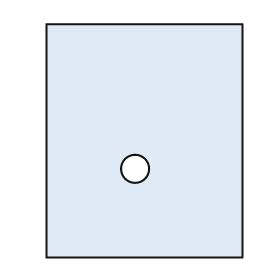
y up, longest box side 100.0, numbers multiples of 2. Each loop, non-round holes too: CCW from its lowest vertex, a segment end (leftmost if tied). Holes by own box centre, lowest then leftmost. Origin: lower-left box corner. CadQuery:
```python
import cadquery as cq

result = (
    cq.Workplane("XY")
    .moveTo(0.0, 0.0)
    .lineTo(84.0, 0.0)
    .lineTo(84.0, 100.0)
    .lineTo(0.0, 100.0)
    .close()
    .moveTo(38.0, 38.0)
    .circle(6.0)
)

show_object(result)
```